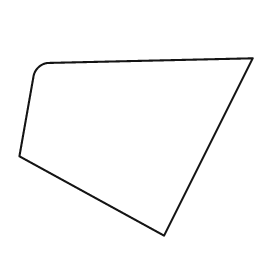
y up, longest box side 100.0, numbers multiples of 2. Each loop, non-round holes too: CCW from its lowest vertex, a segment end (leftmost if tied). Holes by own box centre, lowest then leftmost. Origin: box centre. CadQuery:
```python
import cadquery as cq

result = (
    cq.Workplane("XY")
    .moveTo(12.0, -38.0)
    .lineTo(50.0, 38.0)
    .lineTo(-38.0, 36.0)
    .threePointArc((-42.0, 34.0), (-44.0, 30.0))
    .lineTo(-50.0, -4.0)
    .close()
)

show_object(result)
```